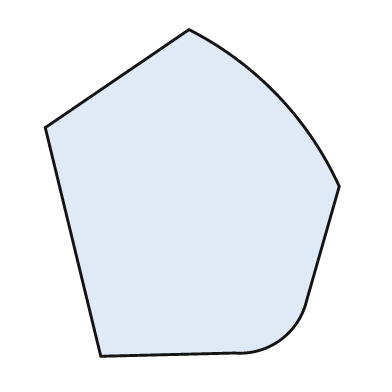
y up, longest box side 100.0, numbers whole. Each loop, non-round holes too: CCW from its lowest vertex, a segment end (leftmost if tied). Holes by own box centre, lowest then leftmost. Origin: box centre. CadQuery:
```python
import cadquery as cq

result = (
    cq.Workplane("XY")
    .moveTo(-28.0, -50.0)
    .lineTo(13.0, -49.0)
    .threePointArc((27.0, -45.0), (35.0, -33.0))
    .lineTo(45.0, 2.0)
    .threePointArc((26.0, 30.0), (-1.0, 50.0))
    .lineTo(-45.0, 20.0)
    .close()
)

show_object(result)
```